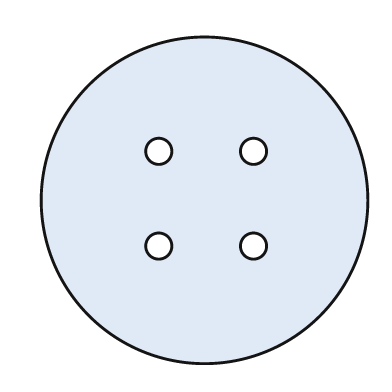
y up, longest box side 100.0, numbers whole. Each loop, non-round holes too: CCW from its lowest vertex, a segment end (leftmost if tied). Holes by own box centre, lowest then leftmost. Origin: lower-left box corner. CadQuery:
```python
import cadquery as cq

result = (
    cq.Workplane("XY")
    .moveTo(50.0, 50.0)
    .circle(50.0)
    .moveTo(36.0, 36.0)
    .circle(4.0)
    .moveTo(65.0, 36.0)
    .circle(4.0)
    .moveTo(36.0, 65.0)
    .circle(4.0)
    .moveTo(65.0, 65.0)
    .circle(4.0)
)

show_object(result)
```